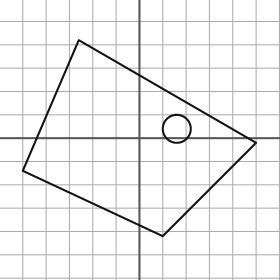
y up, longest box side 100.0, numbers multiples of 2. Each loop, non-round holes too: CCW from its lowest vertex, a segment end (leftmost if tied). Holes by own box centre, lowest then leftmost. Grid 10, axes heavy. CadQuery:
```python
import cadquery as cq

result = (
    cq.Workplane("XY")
    .moveTo(10.0, -42.0)
    .lineTo(50.0, -2.0)
    .lineTo(-26.0, 42.0)
    .lineTo(-50.0, -14.0)
    .close()
    .moveTo(16.0, 4.0)
    .circle(6.0)
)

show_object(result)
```